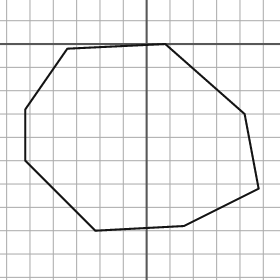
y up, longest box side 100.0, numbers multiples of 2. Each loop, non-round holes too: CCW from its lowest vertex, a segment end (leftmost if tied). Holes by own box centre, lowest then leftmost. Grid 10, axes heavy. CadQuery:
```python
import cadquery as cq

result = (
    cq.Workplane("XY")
    .moveTo(-22.0, -80.0)
    .lineTo(16.0, -78.0)
    .lineTo(48.0, -62.0)
    .lineTo(42.0, -30.0)
    .lineTo(8.0, 0.0)
    .lineTo(-34.0, -2.0)
    .lineTo(-52.0, -28.0)
    .lineTo(-52.0, -50.0)
    .close()
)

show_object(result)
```